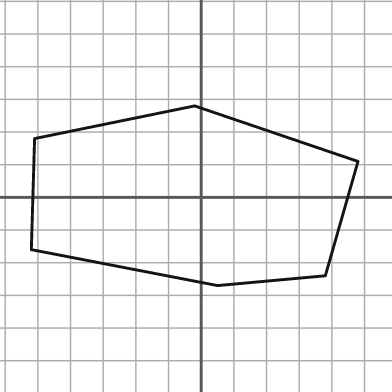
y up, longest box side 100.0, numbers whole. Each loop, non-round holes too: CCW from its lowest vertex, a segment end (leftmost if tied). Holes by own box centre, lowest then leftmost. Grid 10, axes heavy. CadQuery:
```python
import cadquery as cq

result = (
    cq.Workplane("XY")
    .moveTo(5.0, -27.0)
    .lineTo(38.0, -24.0)
    .lineTo(48.0, 11.0)
    .lineTo(-2.0, 28.0)
    .lineTo(-51.0, 18.0)
    .lineTo(-52.0, -16.0)
    .close()
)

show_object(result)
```